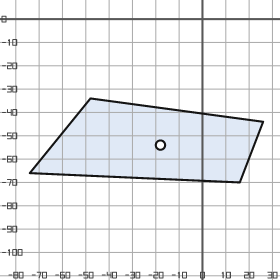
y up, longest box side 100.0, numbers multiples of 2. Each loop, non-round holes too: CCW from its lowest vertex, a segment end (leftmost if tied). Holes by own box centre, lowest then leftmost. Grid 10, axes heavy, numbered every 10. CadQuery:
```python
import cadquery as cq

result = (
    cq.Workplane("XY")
    .moveTo(16.0, -70.0)
    .lineTo(26.0, -44.0)
    .lineTo(-48.0, -34.0)
    .lineTo(-74.0, -66.0)
    .close()
    .moveTo(-18.0, -54.0)
    .circle(2.0)
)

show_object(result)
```